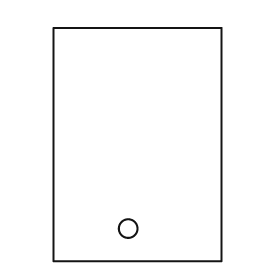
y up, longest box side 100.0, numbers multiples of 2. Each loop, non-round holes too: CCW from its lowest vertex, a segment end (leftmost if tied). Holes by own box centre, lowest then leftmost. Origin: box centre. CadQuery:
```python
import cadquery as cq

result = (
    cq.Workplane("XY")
    .moveTo(-36.0, -50.0)
    .lineTo(36.0, -50.0)
    .lineTo(36.0, 50.0)
    .lineTo(-36.0, 50.0)
    .close()
    .moveTo(-4.0, -36.0)
    .circle(4.0)
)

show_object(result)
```